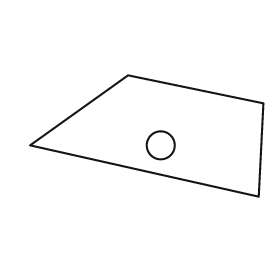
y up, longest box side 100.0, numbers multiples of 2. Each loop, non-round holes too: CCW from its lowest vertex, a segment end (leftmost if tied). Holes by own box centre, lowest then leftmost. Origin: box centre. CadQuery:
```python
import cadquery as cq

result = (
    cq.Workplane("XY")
    .moveTo(48.0, -26.0)
    .lineTo(50.0, 14.0)
    .lineTo(-8.0, 26.0)
    .lineTo(-50.0, -4.0)
    .close()
    .moveTo(6.0, -4.0)
    .circle(6.0)
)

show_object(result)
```